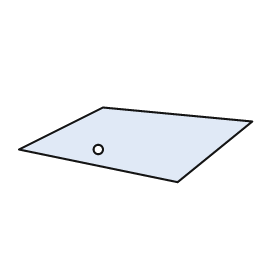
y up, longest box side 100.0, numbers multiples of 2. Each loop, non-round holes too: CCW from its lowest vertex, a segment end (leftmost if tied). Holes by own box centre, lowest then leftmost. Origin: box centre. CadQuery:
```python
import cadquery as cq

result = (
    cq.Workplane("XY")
    .moveTo(18.0, -16.0)
    .lineTo(50.0, 10.0)
    .lineTo(-14.0, 16.0)
    .lineTo(-50.0, -2.0)
    .close()
    .moveTo(-16.0, -2.0)
    .circle(2.0)
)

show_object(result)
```